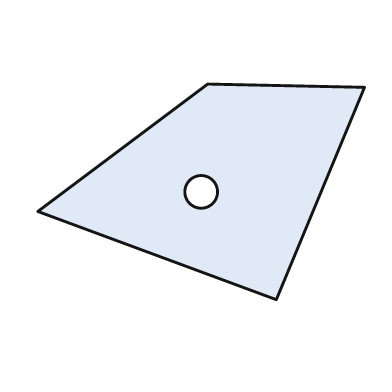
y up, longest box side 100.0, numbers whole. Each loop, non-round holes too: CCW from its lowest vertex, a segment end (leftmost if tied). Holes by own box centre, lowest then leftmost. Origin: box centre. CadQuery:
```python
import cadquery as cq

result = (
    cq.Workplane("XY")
    .moveTo(23.0, -33.0)
    .lineTo(50.0, 32.0)
    .lineTo(2.0, 33.0)
    .lineTo(-50.0, -6.0)
    .close()
    .moveTo(0.0, 0.0)
    .circle(5.0)
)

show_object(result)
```